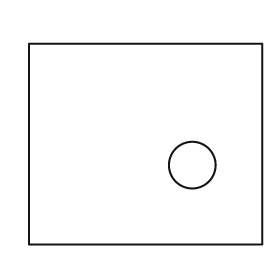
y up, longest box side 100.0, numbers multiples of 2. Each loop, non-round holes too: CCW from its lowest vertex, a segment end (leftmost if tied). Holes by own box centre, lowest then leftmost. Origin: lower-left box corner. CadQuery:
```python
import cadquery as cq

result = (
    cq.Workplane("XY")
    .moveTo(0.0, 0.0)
    .lineTo(100.0, 0.0)
    .lineTo(100.0, 86.0)
    .lineTo(0.0, 86.0)
    .close()
    .moveTo(70.0, 34.0)
    .circle(10.0)
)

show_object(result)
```